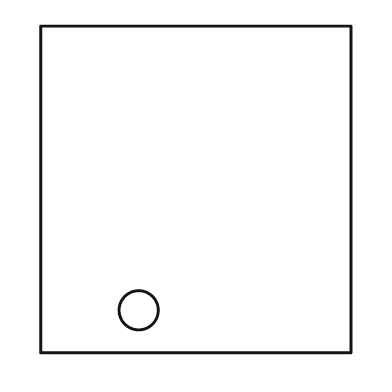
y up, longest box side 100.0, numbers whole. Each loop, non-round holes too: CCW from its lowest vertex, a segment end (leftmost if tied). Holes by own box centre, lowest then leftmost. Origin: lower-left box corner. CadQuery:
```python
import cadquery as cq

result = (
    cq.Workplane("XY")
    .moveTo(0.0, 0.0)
    .lineTo(95.0, 0.0)
    .lineTo(95.0, 100.0)
    .lineTo(0.0, 100.0)
    .close()
    .moveTo(30.0, 13.0)
    .circle(6.0)
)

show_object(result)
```